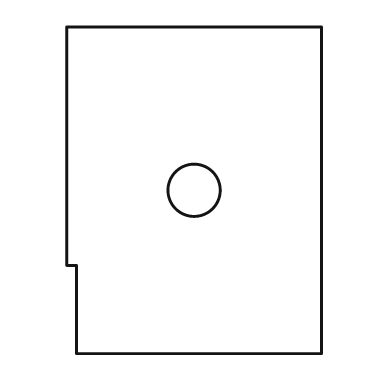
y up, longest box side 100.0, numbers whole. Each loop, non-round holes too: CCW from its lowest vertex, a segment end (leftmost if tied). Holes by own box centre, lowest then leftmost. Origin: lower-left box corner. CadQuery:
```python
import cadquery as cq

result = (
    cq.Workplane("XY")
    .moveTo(3.0, 0.0)
    .lineTo(78.0, 0.0)
    .lineTo(78.0, 100.0)
    .lineTo(0.0, 100.0)
    .lineTo(0.0, 27.0)
    .lineTo(3.0, 27.0)
    .close()
    .moveTo(39.0, 50.0)
    .circle(8.0)
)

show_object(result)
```